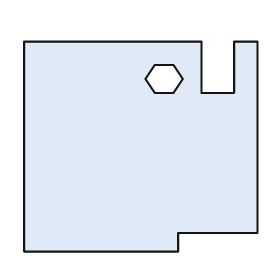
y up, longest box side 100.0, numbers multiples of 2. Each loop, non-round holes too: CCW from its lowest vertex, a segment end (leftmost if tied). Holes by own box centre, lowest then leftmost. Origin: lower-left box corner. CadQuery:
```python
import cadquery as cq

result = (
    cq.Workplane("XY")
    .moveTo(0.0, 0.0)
    .lineTo(66.0, 0.0)
    .lineTo(66.0, 8.0)
    .lineTo(100.0, 8.0)
    .lineTo(100.0, 90.0)
    .lineTo(90.0, 90.0)
    .lineTo(90.0, 68.0)
    .lineTo(76.0, 68.0)
    .lineTo(76.0, 90.0)
    .lineTo(0.0, 90.0)
    .close()
    .moveTo(56.0, 68.0)
    .lineTo(64.0, 68.0)
    .lineTo(68.0, 74.0)
    .lineTo(64.0, 80.0)
    .lineTo(56.0, 80.0)
    .lineTo(52.0, 74.0)
    .close()
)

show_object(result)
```